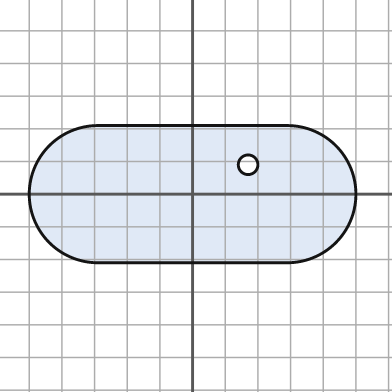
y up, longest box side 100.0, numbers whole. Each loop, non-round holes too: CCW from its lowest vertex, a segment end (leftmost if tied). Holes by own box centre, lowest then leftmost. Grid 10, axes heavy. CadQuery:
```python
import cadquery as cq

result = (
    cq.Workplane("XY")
    .moveTo(-29.0, -21.0)
    .lineTo(29.0, -21.0)
    .threePointArc((50.0, 0.0), (29.0, 21.0))
    .lineTo(-29.0, 21.0)
    .threePointArc((-50.0, 0.0), (-29.0, -21.0))
    .close()
    .moveTo(17.0, 9.0)
    .circle(3.0)
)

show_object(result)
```